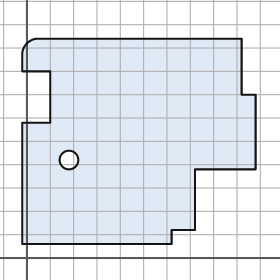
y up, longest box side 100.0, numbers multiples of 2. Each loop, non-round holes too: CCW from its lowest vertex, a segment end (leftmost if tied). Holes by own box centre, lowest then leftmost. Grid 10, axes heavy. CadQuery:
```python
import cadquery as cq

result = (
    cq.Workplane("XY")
    .moveTo(-2.0, 6.0)
    .lineTo(62.0, 6.0)
    .lineTo(62.0, 12.0)
    .lineTo(72.0, 12.0)
    .lineTo(72.0, 38.0)
    .lineTo(98.0, 38.0)
    .lineTo(98.0, 70.0)
    .lineTo(92.0, 70.0)
    .lineTo(92.0, 94.0)
    .lineTo(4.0, 94.0)
    .threePointArc((0.0, 92.0), (-2.0, 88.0))
    .lineTo(-2.0, 80.0)
    .lineTo(10.0, 80.0)
    .lineTo(10.0, 58.0)
    .lineTo(-2.0, 58.0)
    .close()
    .moveTo(18.0, 42.0)
    .circle(4.0)
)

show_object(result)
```